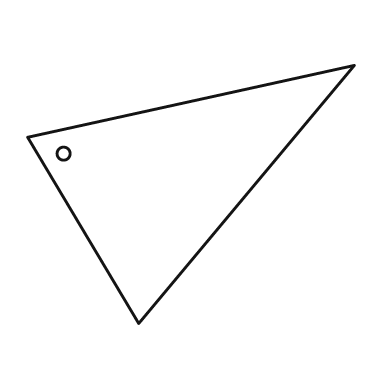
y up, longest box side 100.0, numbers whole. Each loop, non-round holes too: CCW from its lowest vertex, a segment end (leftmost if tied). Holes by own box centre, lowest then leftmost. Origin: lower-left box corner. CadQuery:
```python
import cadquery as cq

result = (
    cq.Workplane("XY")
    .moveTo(34.0, 0.0)
    .lineTo(100.0, 79.0)
    .lineTo(0.0, 57.0)
    .close()
    .moveTo(11.0, 52.0)
    .circle(2.0)
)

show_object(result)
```